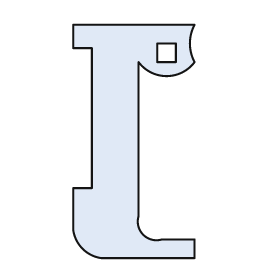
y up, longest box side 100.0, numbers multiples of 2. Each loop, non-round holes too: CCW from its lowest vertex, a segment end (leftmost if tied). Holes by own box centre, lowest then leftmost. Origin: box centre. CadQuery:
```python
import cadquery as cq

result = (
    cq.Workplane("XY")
    .moveTo(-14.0, -50.0)
    .lineTo(26.0, -50.0)
    .lineTo(26.0, -42.0)
    .lineTo(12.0, -42.0)
    .threePointArc((4.0, -40.0), (2.0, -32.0))
    .lineTo(2.0, 34.0)
    .threePointArc((14.0, 28.0), (26.0, 34.0))
    .threePointArc((24.0, 42.0), (26.0, 50.0))
    .lineTo(-26.0, 50.0)
    .lineTo(-26.0, 40.0)
    .lineTo(-18.0, 40.0)
    .lineTo(-18.0, -20.0)
    .lineTo(-26.0, -20.0)
    .lineTo(-26.0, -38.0)
    .threePointArc((-22.0, -46.0), (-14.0, -50.0))
    .close()
    .moveTo(10.0, 34.0)
    .lineTo(18.0, 34.0)
    .lineTo(18.0, 42.0)
    .lineTo(10.0, 42.0)
    .close()
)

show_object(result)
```